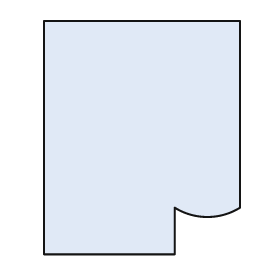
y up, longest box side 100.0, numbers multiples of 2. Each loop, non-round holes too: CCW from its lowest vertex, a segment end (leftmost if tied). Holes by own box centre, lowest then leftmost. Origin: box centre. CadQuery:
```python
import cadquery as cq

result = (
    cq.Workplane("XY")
    .moveTo(-42.0, -50.0)
    .lineTo(14.0, -50.0)
    .lineTo(14.0, -30.0)
    .threePointArc((28.0, -34.0), (42.0, -30.0))
    .lineTo(42.0, 50.0)
    .lineTo(-42.0, 50.0)
    .close()
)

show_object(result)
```